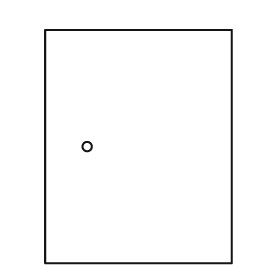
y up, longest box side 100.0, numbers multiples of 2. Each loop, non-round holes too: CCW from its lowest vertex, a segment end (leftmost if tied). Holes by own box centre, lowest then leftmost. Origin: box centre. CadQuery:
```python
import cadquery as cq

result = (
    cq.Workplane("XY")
    .moveTo(-40.0, -50.0)
    .lineTo(40.0, -50.0)
    .lineTo(40.0, 50.0)
    .lineTo(-40.0, 50.0)
    .close()
    .moveTo(-22.0, 0.0)
    .circle(2.0)
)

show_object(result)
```